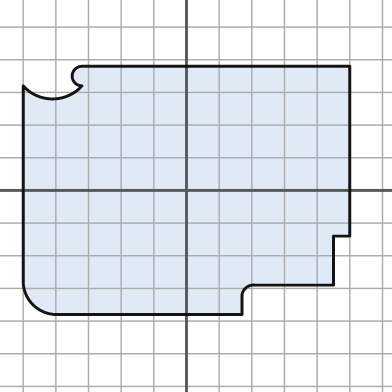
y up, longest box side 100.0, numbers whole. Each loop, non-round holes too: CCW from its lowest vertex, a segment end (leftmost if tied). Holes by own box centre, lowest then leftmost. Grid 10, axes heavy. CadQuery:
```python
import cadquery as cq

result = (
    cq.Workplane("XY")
    .moveTo(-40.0, -38.0)
    .lineTo(17.0, -38.0)
    .lineTo(17.0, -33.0)
    .threePointArc((18.0, -30.0), (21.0, -29.0))
    .lineTo(45.0, -29.0)
    .lineTo(45.0, -14.0)
    .lineTo(50.0, -14.0)
    .lineTo(50.0, 38.0)
    .lineTo(-32.0, 38.0)
    .threePointArc((-35.0, 35.0), (-32.0, 32.0))
    .threePointArc((-41.0, 28.0), (-50.0, 32.0))
    .lineTo(-50.0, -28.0)
    .threePointArc((-47.0, -35.0), (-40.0, -38.0))
    .close()
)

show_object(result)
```